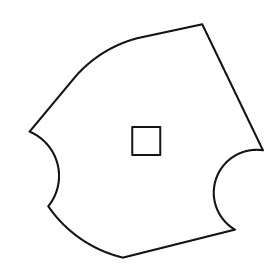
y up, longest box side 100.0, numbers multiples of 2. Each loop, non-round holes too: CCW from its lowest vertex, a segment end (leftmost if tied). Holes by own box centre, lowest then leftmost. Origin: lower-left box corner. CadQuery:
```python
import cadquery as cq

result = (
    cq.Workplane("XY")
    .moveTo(40.0, 0.0)
    .lineTo(88.0, 12.0)
    .threePointArc((80.0, 34.0), (100.0, 46.0))
    .lineTo(74.0, 100.0)
    .lineTo(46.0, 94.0)
    .threePointArc((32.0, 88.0), (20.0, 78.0))
    .lineTo(0.0, 54.0)
    .threePointArc((12.0, 40.0), (8.0, 22.0))
    .threePointArc((22.0, 8.0), (40.0, 0.0))
    .close()
    .moveTo(44.0, 44.0)
    .lineTo(56.0, 44.0)
    .lineTo(56.0, 56.0)
    .lineTo(44.0, 56.0)
    .close()
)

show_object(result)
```